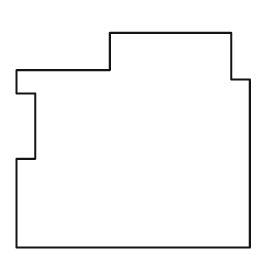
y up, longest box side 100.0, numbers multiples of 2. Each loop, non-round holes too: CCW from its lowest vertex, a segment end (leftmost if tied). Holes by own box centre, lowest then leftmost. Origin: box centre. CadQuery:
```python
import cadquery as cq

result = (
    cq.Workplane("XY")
    .moveTo(-50.0, -46.0)
    .lineTo(50.0, -46.0)
    .lineTo(50.0, 26.0)
    .lineTo(42.0, 26.0)
    .lineTo(42.0, 46.0)
    .lineTo(-10.0, 46.0)
    .lineTo(-10.0, 30.0)
    .lineTo(-50.0, 30.0)
    .lineTo(-50.0, 20.0)
    .lineTo(-42.0, 20.0)
    .lineTo(-42.0, -8.0)
    .lineTo(-50.0, -8.0)
    .close()
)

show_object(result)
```